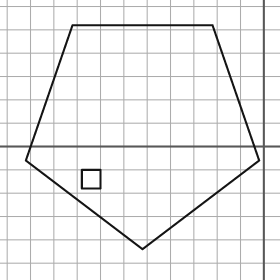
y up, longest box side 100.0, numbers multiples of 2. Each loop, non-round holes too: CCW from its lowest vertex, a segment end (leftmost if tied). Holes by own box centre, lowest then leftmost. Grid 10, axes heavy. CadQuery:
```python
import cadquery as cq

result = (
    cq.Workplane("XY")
    .moveTo(-52.0, -44.0)
    .lineTo(-2.0, -6.0)
    .lineTo(-22.0, 52.0)
    .lineTo(-82.0, 52.0)
    .lineTo(-102.0, -6.0)
    .close()
    .moveTo(-78.0, -18.0)
    .lineTo(-70.0, -18.0)
    .lineTo(-70.0, -10.0)
    .lineTo(-78.0, -10.0)
    .close()
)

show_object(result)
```